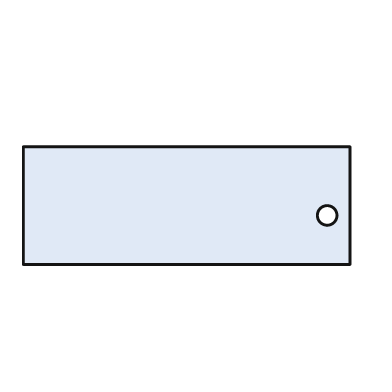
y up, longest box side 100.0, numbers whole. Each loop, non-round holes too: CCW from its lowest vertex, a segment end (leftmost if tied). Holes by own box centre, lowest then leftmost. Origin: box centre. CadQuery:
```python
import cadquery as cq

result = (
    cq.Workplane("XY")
    .moveTo(-50.0, -18.0)
    .lineTo(50.0, -18.0)
    .lineTo(50.0, 18.0)
    .lineTo(-50.0, 18.0)
    .close()
    .moveTo(43.0, -3.0)
    .circle(3.0)
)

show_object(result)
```